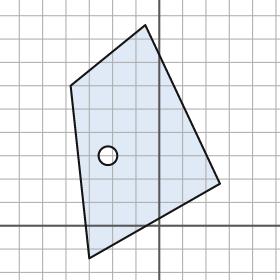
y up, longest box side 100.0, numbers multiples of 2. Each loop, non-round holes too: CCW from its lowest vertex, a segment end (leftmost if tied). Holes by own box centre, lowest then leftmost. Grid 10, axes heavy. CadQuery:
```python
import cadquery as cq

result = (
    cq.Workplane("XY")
    .moveTo(-30.0, -14.0)
    .lineTo(26.0, 18.0)
    .lineTo(-6.0, 86.0)
    .lineTo(-38.0, 60.0)
    .close()
    .moveTo(-22.0, 30.0)
    .circle(4.0)
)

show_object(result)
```